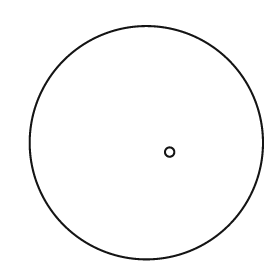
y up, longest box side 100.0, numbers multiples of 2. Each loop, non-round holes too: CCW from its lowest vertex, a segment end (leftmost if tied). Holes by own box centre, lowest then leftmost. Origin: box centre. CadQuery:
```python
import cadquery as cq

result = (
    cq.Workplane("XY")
    .moveTo(0.0, 0.0)
    .circle(50.0)
    .moveTo(10.0, -4.0)
    .circle(2.0)
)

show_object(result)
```